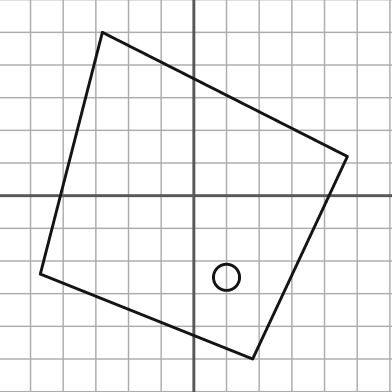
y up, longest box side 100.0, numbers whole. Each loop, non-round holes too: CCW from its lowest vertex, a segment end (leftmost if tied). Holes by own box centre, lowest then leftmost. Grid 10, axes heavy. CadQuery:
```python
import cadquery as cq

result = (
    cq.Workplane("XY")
    .moveTo(18.0, -50.0)
    .lineTo(47.0, 12.0)
    .lineTo(-28.0, 50.0)
    .lineTo(-47.0, -24.0)
    .close()
    .moveTo(10.0, -25.0)
    .circle(4.0)
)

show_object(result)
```